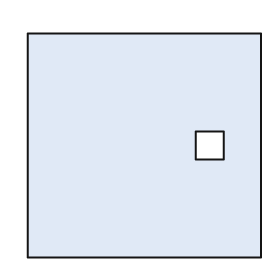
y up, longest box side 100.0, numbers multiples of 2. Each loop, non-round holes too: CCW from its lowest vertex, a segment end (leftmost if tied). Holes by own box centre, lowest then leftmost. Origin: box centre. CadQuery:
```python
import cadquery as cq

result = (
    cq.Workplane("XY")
    .moveTo(-50.0, -48.0)
    .lineTo(50.0, -48.0)
    .lineTo(50.0, 48.0)
    .lineTo(-50.0, 48.0)
    .close()
    .moveTo(22.0, -6.0)
    .lineTo(34.0, -6.0)
    .lineTo(34.0, 6.0)
    .lineTo(22.0, 6.0)
    .close()
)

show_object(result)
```